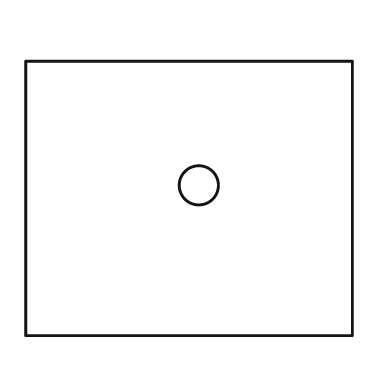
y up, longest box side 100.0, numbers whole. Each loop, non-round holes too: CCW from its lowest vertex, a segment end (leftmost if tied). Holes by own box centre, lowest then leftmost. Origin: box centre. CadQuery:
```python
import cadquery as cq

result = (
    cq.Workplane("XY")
    .moveTo(-50.0, -42.0)
    .lineTo(50.0, -42.0)
    .lineTo(50.0, 42.0)
    .lineTo(-50.0, 42.0)
    .close()
    .moveTo(3.0, 4.0)
    .circle(6.0)
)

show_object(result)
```